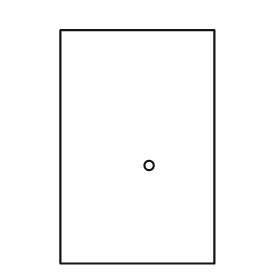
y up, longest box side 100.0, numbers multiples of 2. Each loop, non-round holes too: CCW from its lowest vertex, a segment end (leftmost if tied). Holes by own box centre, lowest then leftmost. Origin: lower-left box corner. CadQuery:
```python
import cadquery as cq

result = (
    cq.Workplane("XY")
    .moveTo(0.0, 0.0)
    .lineTo(66.0, 0.0)
    .lineTo(66.0, 100.0)
    .lineTo(0.0, 100.0)
    .close()
    .moveTo(38.0, 42.0)
    .circle(2.0)
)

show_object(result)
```